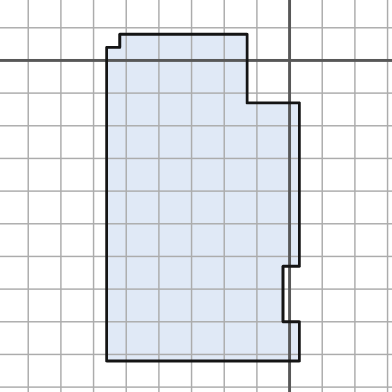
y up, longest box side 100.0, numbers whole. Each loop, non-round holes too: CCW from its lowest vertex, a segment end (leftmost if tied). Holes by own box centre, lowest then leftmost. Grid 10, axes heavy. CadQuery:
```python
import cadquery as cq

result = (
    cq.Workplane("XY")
    .moveTo(-56.0, -92.0)
    .lineTo(3.0, -92.0)
    .lineTo(3.0, -80.0)
    .lineTo(-2.0, -80.0)
    .lineTo(-2.0, -63.0)
    .lineTo(3.0, -63.0)
    .lineTo(3.0, -13.0)
    .lineTo(-13.0, -13.0)
    .lineTo(-13.0, 8.0)
    .lineTo(-52.0, 8.0)
    .lineTo(-52.0, 4.0)
    .lineTo(-56.0, 4.0)
    .close()
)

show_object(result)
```